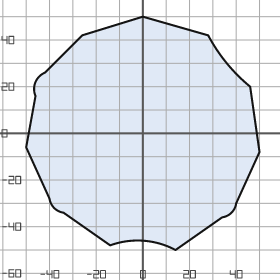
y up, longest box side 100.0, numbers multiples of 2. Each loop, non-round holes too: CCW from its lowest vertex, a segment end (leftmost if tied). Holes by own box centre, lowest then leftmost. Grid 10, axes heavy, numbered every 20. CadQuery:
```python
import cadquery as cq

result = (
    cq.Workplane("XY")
    .moveTo(14.0, -50.0)
    .lineTo(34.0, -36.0)
    .threePointArc((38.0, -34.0), (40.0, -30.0))
    .lineTo(50.0, -8.0)
    .lineTo(46.0, 20.0)
    .threePointArc((36.0, 30.0), (28.0, 42.0))
    .lineTo(0.0, 50.0)
    .lineTo(-26.0, 42.0)
    .lineTo(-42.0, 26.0)
    .threePointArc((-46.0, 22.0), (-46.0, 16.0))
    .lineTo(-50.0, -6.0)
    .lineTo(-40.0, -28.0)
    .threePointArc((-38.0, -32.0), (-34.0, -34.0))
    .lineTo(-14.0, -48.0)
    .threePointArc((0.0, -46.0), (14.0, -50.0))
    .close()
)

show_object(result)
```